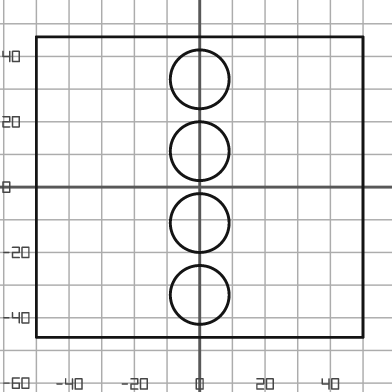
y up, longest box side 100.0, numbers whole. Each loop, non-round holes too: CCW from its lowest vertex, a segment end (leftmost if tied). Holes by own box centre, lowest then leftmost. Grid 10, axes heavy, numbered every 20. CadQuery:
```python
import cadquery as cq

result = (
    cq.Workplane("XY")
    .moveTo(-50.0, -46.0)
    .lineTo(50.0, -46.0)
    .lineTo(50.0, 46.0)
    .lineTo(-50.0, 46.0)
    .close()
    .moveTo(0.0, -33.0)
    .circle(9.0)
    .moveTo(0.0, -11.0)
    .circle(9.0)
    .moveTo(0.0, 11.0)
    .circle(9.0)
    .moveTo(0.0, 33.0)
    .circle(9.0)
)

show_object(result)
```